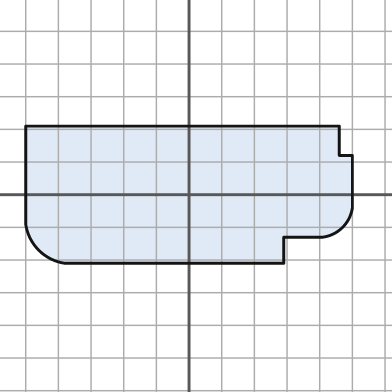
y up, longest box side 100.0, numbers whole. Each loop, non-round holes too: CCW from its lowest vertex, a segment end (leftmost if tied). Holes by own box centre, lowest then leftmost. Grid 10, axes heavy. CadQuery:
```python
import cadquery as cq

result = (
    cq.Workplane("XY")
    .moveTo(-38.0, -21.0)
    .lineTo(29.0, -21.0)
    .lineTo(29.0, -13.0)
    .lineTo(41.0, -13.0)
    .threePointArc((47.0, -10.0), (50.0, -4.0))
    .lineTo(50.0, 12.0)
    .lineTo(46.0, 12.0)
    .lineTo(46.0, 21.0)
    .lineTo(-50.0, 21.0)
    .lineTo(-50.0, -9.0)
    .threePointArc((-46.0, -17.0), (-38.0, -21.0))
    .close()
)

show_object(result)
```